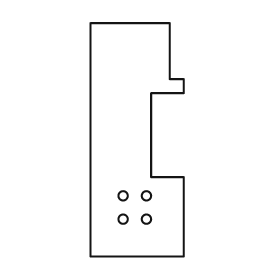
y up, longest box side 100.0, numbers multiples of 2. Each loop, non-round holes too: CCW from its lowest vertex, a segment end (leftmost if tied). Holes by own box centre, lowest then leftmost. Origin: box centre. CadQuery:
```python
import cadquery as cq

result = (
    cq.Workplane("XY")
    .moveTo(-20.0, -50.0)
    .lineTo(20.0, -50.0)
    .lineTo(20.0, -16.0)
    .lineTo(6.0, -16.0)
    .lineTo(6.0, 20.0)
    .lineTo(20.0, 20.0)
    .lineTo(20.0, 26.0)
    .lineTo(14.0, 26.0)
    .lineTo(14.0, 50.0)
    .lineTo(-20.0, 50.0)
    .close()
    .moveTo(-6.0, -34.0)
    .circle(2.0)
    .moveTo(4.0, -34.0)
    .circle(2.0)
    .moveTo(-6.0, -24.0)
    .circle(2.0)
    .moveTo(4.0, -24.0)
    .circle(2.0)
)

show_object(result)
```